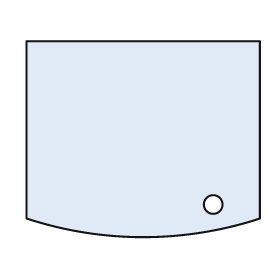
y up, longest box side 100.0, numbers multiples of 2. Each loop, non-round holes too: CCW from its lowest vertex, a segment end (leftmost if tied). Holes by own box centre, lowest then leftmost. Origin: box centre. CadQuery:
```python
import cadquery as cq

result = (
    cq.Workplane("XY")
    .moveTo(-50.0, -34.0)
    .threePointArc((0.0, -42.0), (50.0, -34.0))
    .lineTo(50.0, 42.0)
    .lineTo(-50.0, 42.0)
    .close()
    .moveTo(30.0, -28.0)
    .circle(4.0)
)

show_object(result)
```